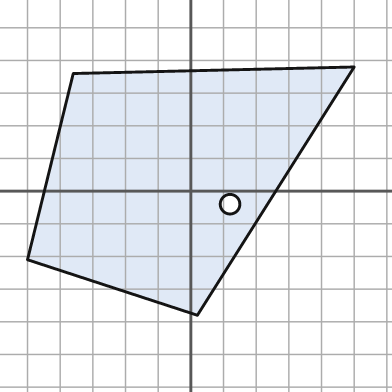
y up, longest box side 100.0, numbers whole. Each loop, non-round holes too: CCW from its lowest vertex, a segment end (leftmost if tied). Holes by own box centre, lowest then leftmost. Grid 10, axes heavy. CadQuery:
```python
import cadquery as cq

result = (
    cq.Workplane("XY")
    .moveTo(2.0, -38.0)
    .lineTo(50.0, 38.0)
    .lineTo(-36.0, 36.0)
    .lineTo(-50.0, -21.0)
    .close()
    .moveTo(12.0, -4.0)
    .circle(3.0)
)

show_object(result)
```